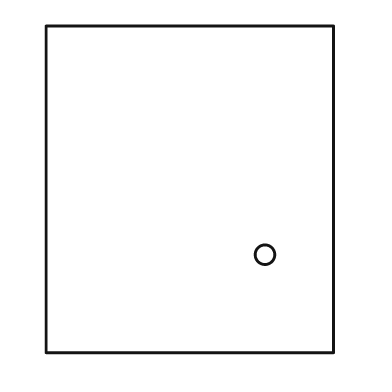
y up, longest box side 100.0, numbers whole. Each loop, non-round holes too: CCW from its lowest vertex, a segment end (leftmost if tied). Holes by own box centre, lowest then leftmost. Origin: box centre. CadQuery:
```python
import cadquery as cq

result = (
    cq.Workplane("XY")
    .moveTo(-44.0, -50.0)
    .lineTo(44.0, -50.0)
    .lineTo(44.0, 50.0)
    .lineTo(-44.0, 50.0)
    .close()
    .moveTo(23.0, -20.0)
    .circle(3.0)
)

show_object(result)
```